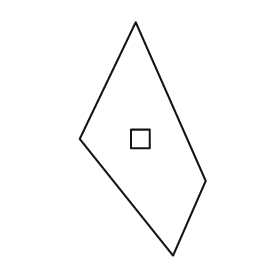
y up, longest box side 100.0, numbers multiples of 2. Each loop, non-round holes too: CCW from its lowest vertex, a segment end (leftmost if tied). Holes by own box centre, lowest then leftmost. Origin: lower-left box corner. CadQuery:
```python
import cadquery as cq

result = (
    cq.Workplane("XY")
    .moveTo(40.0, 0.0)
    .lineTo(54.0, 32.0)
    .lineTo(24.0, 100.0)
    .lineTo(0.0, 50.0)
    .close()
    .moveTo(22.0, 46.0)
    .lineTo(30.0, 46.0)
    .lineTo(30.0, 54.0)
    .lineTo(22.0, 54.0)
    .close()
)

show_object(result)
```